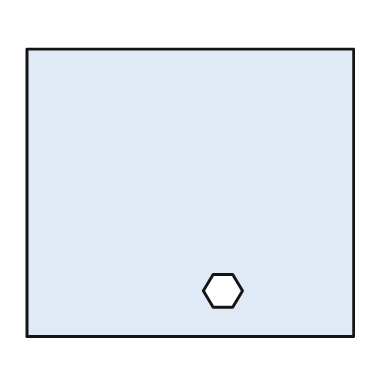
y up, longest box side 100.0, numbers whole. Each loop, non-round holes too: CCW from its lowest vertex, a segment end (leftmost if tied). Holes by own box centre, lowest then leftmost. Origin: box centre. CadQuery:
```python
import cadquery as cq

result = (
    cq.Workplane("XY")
    .moveTo(-50.0, -44.0)
    .lineTo(50.0, -44.0)
    .lineTo(50.0, 44.0)
    .lineTo(-50.0, 44.0)
    .close()
    .moveTo(7.0, -35.0)
    .lineTo(13.0, -35.0)
    .lineTo(16.0, -30.0)
    .lineTo(13.0, -25.0)
    .lineTo(7.0, -25.0)
    .lineTo(4.0, -30.0)
    .close()
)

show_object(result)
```